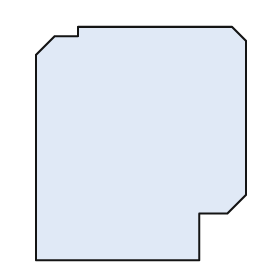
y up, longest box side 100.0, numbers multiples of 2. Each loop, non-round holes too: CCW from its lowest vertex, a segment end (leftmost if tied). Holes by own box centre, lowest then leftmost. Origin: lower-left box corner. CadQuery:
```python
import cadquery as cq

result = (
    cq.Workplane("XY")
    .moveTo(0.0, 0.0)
    .lineTo(70.0, 0.0)
    .lineTo(70.0, 20.0)
    .lineTo(82.0, 20.0)
    .lineTo(90.0, 28.0)
    .lineTo(90.0, 94.0)
    .lineTo(84.0, 100.0)
    .lineTo(18.0, 100.0)
    .lineTo(18.0, 96.0)
    .lineTo(8.0, 96.0)
    .lineTo(0.0, 88.0)
    .close()
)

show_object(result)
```